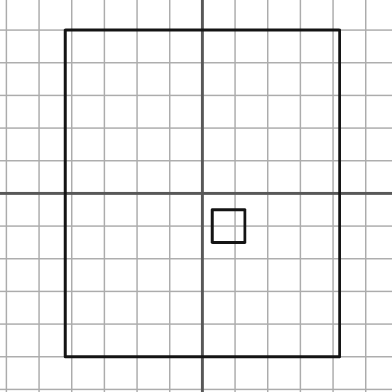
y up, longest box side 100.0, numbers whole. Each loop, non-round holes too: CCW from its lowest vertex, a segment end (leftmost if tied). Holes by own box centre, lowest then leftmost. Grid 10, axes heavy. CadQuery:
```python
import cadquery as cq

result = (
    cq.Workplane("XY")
    .moveTo(-42.0, -50.0)
    .lineTo(42.0, -50.0)
    .lineTo(42.0, 50.0)
    .lineTo(-42.0, 50.0)
    .close()
    .moveTo(3.0, -15.0)
    .lineTo(13.0, -15.0)
    .lineTo(13.0, -5.0)
    .lineTo(3.0, -5.0)
    .close()
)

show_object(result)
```